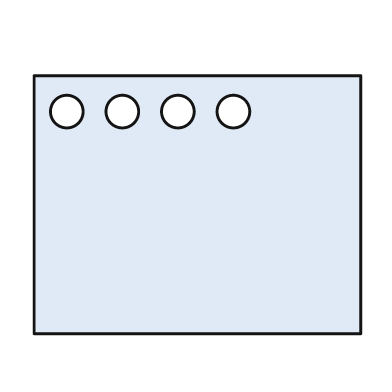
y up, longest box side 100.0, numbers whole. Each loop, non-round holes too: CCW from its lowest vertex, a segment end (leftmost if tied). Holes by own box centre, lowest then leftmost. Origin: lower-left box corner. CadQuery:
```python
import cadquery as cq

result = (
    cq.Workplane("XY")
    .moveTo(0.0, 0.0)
    .lineTo(100.0, 0.0)
    .lineTo(100.0, 79.0)
    .lineTo(0.0, 79.0)
    .close()
    .moveTo(10.0, 68.0)
    .circle(5.0)
    .moveTo(27.0, 68.0)
    .circle(5.0)
    .moveTo(44.0, 68.0)
    .circle(5.0)
    .moveTo(61.0, 68.0)
    .circle(5.0)
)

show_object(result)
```